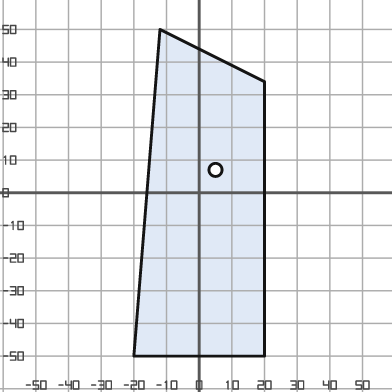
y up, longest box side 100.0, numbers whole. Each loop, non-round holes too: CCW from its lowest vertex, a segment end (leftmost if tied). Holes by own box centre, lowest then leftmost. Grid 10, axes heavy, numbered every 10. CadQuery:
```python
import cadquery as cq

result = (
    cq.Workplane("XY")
    .moveTo(-20.0, -50.0)
    .lineTo(20.0, -50.0)
    .lineTo(20.0, 34.0)
    .lineTo(-12.0, 50.0)
    .close()
    .moveTo(5.0, 7.0)
    .circle(2.0)
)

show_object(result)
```